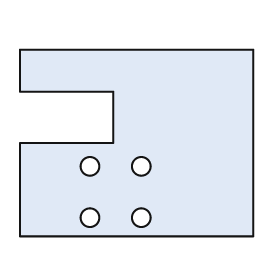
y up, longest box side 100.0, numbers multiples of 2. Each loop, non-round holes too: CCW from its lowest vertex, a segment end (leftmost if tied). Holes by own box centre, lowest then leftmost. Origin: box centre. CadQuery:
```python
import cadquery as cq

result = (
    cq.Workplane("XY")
    .moveTo(-50.0, -40.0)
    .lineTo(50.0, -40.0)
    .lineTo(50.0, 40.0)
    .lineTo(-50.0, 40.0)
    .lineTo(-50.0, 22.0)
    .lineTo(-10.0, 22.0)
    .lineTo(-10.0, 0.0)
    .lineTo(-50.0, 0.0)
    .close()
    .moveTo(-20.0, -32.0)
    .circle(4.0)
    .moveTo(2.0, -32.0)
    .circle(4.0)
    .moveTo(-20.0, -10.0)
    .circle(4.0)
    .moveTo(2.0, -10.0)
    .circle(4.0)
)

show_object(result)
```